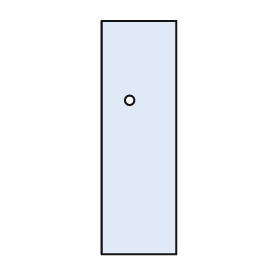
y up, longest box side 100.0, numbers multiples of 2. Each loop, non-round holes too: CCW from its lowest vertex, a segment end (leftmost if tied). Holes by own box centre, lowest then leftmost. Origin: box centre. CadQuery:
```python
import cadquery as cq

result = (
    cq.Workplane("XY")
    .moveTo(-16.0, -50.0)
    .lineTo(16.0, -50.0)
    .lineTo(16.0, 50.0)
    .lineTo(-16.0, 50.0)
    .close()
    .moveTo(-4.0, 16.0)
    .circle(2.0)
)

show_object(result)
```